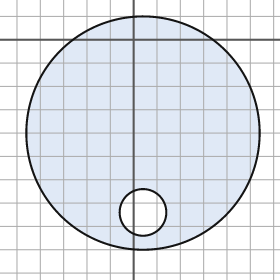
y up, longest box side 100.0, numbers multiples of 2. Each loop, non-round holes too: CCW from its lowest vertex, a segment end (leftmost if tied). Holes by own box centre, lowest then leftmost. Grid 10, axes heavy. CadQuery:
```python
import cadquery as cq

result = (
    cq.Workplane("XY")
    .moveTo(4.0, -40.0)
    .circle(50.0)
    .moveTo(4.0, -74.0)
    .circle(10.0)
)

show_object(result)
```